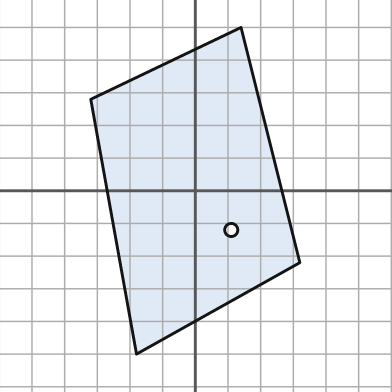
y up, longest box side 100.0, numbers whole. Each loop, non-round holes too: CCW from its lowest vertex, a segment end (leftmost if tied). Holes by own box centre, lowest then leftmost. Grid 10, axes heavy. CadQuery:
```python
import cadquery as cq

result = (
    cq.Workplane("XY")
    .moveTo(-18.0, -50.0)
    .lineTo(32.0, -22.0)
    .lineTo(14.0, 50.0)
    .lineTo(-32.0, 28.0)
    .close()
    .moveTo(11.0, -12.0)
    .circle(2.0)
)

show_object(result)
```